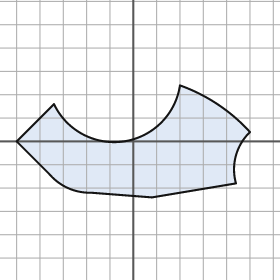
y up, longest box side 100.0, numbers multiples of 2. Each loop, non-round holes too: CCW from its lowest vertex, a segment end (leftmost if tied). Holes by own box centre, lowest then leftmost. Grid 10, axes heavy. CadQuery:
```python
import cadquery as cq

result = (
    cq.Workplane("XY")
    .moveTo(8.0, -24.0)
    .lineTo(44.0, -18.0)
    .threePointArc((44.0, -6.0), (50.0, 4.0))
    .threePointArc((36.0, 16.0), (20.0, 24.0))
    .threePointArc((-4.0, 0.0), (-34.0, 16.0))
    .lineTo(-50.0, 0.0)
    .lineTo(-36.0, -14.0)
    .threePointArc((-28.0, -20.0), (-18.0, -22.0))
    .close()
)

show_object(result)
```